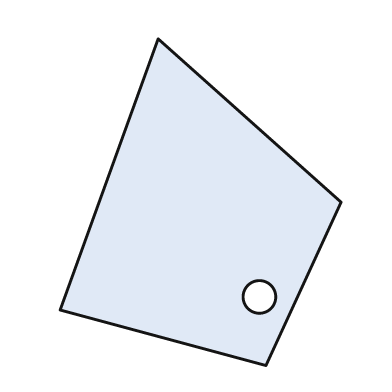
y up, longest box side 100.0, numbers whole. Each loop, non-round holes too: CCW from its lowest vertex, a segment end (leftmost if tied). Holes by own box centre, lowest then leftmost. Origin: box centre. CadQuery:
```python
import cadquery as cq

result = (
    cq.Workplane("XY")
    .moveTo(20.0, -50.0)
    .lineTo(43.0, 0.0)
    .lineTo(-13.0, 50.0)
    .lineTo(-43.0, -33.0)
    .close()
    .moveTo(18.0, -29.0)
    .circle(5.0)
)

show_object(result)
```